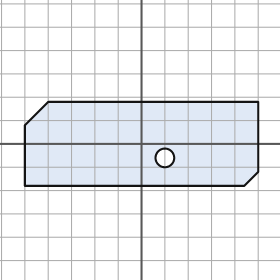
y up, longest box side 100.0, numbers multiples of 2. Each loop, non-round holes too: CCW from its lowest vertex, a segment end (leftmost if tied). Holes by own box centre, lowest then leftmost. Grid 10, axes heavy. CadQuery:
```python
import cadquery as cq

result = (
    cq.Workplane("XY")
    .moveTo(-50.0, -18.0)
    .lineTo(44.0, -18.0)
    .lineTo(50.0, -12.0)
    .lineTo(50.0, 18.0)
    .lineTo(-40.0, 18.0)
    .lineTo(-50.0, 8.0)
    .close()
    .moveTo(10.0, -6.0)
    .circle(4.0)
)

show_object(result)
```